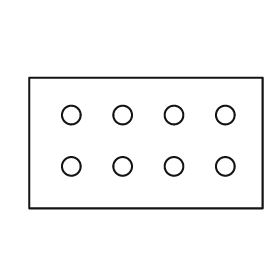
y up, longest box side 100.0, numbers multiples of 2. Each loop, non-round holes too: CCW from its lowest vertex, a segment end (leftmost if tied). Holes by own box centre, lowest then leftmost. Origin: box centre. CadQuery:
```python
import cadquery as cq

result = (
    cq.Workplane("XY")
    .moveTo(-50.0, -28.0)
    .lineTo(50.0, -28.0)
    .lineTo(50.0, 28.0)
    .lineTo(-50.0, 28.0)
    .close()
    .moveTo(-32.0, -10.0)
    .circle(4.0)
    .moveTo(-10.0, -10.0)
    .circle(4.0)
    .moveTo(12.0, -10.0)
    .circle(4.0)
    .moveTo(34.0, -10.0)
    .circle(4.0)
    .moveTo(-32.0, 12.0)
    .circle(4.0)
    .moveTo(-10.0, 12.0)
    .circle(4.0)
    .moveTo(12.0, 12.0)
    .circle(4.0)
    .moveTo(34.0, 12.0)
    .circle(4.0)
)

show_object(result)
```